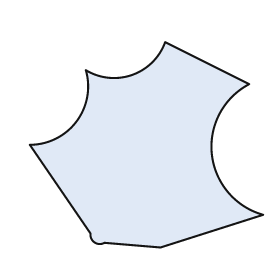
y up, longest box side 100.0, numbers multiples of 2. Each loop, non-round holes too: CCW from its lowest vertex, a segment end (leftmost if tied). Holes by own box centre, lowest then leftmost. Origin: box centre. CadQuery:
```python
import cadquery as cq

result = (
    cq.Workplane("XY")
    .moveTo(6.0, -44.0)
    .lineTo(50.0, -30.0)
    .threePointArc((28.0, -4.0), (44.0, 26.0))
    .lineTo(8.0, 44.0)
    .threePointArc((-6.0, 30.0), (-26.0, 32.0))
    .threePointArc((-30.0, 10.0), (-50.0, 0.0))
    .lineTo(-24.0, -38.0)
    .threePointArc((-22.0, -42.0), (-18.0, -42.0))
    .close()
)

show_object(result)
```